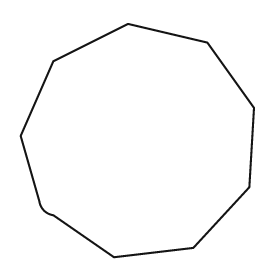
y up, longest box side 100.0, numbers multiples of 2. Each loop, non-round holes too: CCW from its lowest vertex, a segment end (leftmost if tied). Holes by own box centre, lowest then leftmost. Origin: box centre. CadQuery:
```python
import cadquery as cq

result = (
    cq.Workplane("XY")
    .moveTo(-10.0, -50.0)
    .lineTo(24.0, -46.0)
    .lineTo(48.0, -20.0)
    .lineTo(50.0, 14.0)
    .lineTo(30.0, 42.0)
    .lineTo(-4.0, 50.0)
    .lineTo(-36.0, 34.0)
    .lineTo(-50.0, 2.0)
    .lineTo(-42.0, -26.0)
    .threePointArc((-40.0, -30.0), (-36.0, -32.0))
    .close()
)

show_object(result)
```